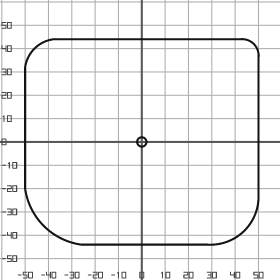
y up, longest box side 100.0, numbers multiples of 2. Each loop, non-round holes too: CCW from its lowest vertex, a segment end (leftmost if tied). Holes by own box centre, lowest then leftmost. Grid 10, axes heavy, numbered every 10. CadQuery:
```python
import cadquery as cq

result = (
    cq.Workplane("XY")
    .moveTo(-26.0, -44.0)
    .lineTo(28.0, -44.0)
    .threePointArc((44.0, -38.0), (50.0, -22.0))
    .lineTo(50.0, 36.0)
    .threePointArc((48.0, 42.0), (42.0, 44.0))
    .lineTo(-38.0, 44.0)
    .threePointArc((-46.0, 40.0), (-50.0, 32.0))
    .lineTo(-50.0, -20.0)
    .threePointArc((-42.0, -36.0), (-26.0, -44.0))
    .close()
    .moveTo(0.0, 0.0)
    .circle(2.0)
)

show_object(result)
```